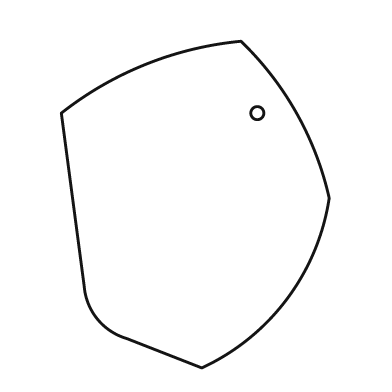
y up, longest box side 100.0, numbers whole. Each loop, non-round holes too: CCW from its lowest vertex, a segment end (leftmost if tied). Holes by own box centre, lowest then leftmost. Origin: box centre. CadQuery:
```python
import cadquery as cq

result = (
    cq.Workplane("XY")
    .moveTo(2.0, -50.0)
    .threePointArc((28.0, -29.0), (41.0, 2.0))
    .threePointArc((31.0, 28.0), (14.0, 50.0))
    .threePointArc((-15.0, 43.0), (-41.0, 28.0))
    .lineTo(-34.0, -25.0)
    .threePointArc((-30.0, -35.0), (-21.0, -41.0))
    .close()
    .moveTo(19.0, 28.0)
    .circle(2.0)
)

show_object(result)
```